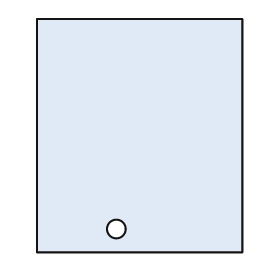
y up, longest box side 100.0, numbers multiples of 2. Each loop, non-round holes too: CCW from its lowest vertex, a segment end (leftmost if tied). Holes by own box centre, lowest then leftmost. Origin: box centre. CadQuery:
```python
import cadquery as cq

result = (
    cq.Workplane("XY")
    .moveTo(-44.0, -50.0)
    .lineTo(44.0, -50.0)
    .lineTo(44.0, 50.0)
    .lineTo(-44.0, 50.0)
    .close()
    .moveTo(-10.0, -40.0)
    .circle(4.0)
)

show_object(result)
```